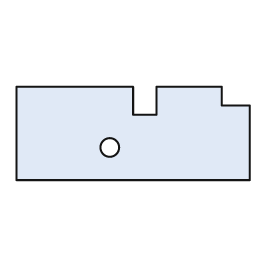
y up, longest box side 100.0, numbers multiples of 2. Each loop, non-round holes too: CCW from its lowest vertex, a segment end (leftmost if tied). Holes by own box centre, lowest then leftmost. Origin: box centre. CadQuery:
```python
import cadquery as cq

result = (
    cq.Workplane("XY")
    .moveTo(-50.0, -20.0)
    .lineTo(50.0, -20.0)
    .lineTo(50.0, 12.0)
    .lineTo(38.0, 12.0)
    .lineTo(38.0, 20.0)
    .lineTo(10.0, 20.0)
    .lineTo(10.0, 8.0)
    .lineTo(0.0, 8.0)
    .lineTo(0.0, 20.0)
    .lineTo(-50.0, 20.0)
    .close()
    .moveTo(-10.0, -6.0)
    .circle(4.0)
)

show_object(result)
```